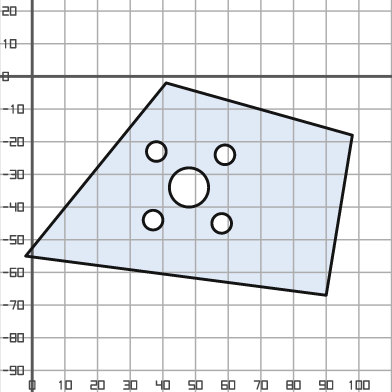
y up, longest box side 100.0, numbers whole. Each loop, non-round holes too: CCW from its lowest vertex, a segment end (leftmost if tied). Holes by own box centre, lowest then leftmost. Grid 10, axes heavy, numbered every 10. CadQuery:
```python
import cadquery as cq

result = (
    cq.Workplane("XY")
    .moveTo(90.0, -67.0)
    .lineTo(98.0, -18.0)
    .lineTo(41.0, -2.0)
    .lineTo(-2.0, -55.0)
    .close()
    .moveTo(58.0, -45.0)
    .circle(3.0)
    .moveTo(37.0, -44.0)
    .circle(3.0)
    .moveTo(48.0, -34.0)
    .circle(6.0)
    .moveTo(59.0, -24.0)
    .circle(3.0)
    .moveTo(38.0, -23.0)
    .circle(3.0)
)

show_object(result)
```